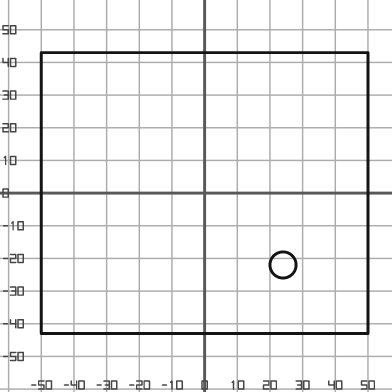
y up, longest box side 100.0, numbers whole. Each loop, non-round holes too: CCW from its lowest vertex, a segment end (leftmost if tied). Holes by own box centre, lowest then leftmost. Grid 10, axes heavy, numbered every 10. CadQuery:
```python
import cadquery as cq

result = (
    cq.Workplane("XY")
    .moveTo(-50.0, -43.0)
    .lineTo(50.0, -43.0)
    .lineTo(50.0, 43.0)
    .lineTo(-50.0, 43.0)
    .close()
    .moveTo(24.0, -22.0)
    .circle(4.0)
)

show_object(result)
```